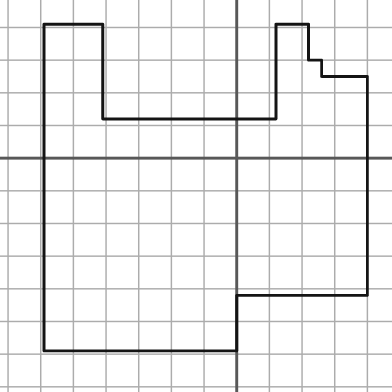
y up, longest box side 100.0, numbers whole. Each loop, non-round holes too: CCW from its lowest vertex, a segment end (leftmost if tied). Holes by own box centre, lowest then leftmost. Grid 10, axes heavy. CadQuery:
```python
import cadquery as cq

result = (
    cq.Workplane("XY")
    .moveTo(-59.0, -59.0)
    .lineTo(0.0, -59.0)
    .lineTo(0.0, -42.0)
    .lineTo(40.0, -42.0)
    .lineTo(40.0, 25.0)
    .lineTo(26.0, 25.0)
    .lineTo(26.0, 30.0)
    .lineTo(22.0, 30.0)
    .lineTo(22.0, 41.0)
    .lineTo(12.0, 41.0)
    .lineTo(12.0, 12.0)
    .lineTo(-41.0, 12.0)
    .lineTo(-41.0, 41.0)
    .lineTo(-59.0, 41.0)
    .close()
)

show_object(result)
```